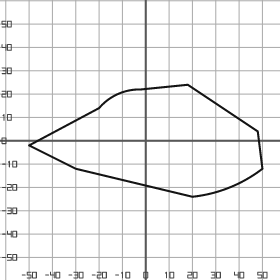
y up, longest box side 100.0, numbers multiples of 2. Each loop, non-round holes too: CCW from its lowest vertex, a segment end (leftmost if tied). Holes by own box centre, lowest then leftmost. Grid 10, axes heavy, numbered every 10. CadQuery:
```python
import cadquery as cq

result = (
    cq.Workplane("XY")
    .moveTo(20.0, -24.0)
    .threePointArc((36.0, -20.0), (50.0, -12.0))
    .lineTo(48.0, 4.0)
    .lineTo(18.0, 24.0)
    .lineTo(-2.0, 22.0)
    .threePointArc((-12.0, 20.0), (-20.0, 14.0))
    .lineTo(-50.0, -2.0)
    .lineTo(-30.0, -12.0)
    .close()
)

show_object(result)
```